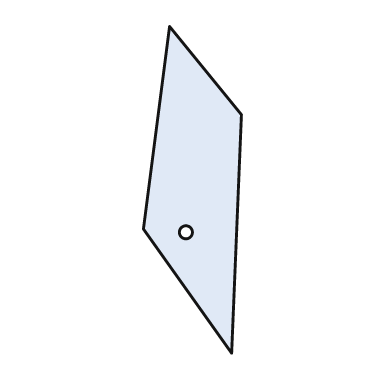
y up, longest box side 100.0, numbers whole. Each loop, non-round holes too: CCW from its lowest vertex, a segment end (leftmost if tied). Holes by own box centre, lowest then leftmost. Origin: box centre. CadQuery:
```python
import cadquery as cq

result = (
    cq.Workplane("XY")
    .moveTo(12.0, -50.0)
    .lineTo(15.0, 23.0)
    .lineTo(-7.0, 50.0)
    .lineTo(-15.0, -12.0)
    .close()
    .moveTo(-2.0, -13.0)
    .circle(2.0)
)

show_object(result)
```